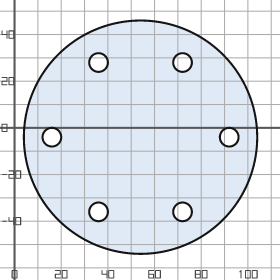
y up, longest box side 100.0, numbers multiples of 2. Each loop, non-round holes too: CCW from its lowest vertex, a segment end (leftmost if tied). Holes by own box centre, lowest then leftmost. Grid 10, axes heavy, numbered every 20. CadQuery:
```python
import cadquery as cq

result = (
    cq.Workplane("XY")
    .moveTo(54.0, -4.0)
    .circle(50.0)
    .moveTo(36.0, -36.0)
    .circle(4.0)
    .moveTo(72.0, -36.0)
    .circle(4.0)
    .moveTo(16.0, -4.0)
    .circle(4.0)
    .moveTo(92.0, -4.0)
    .circle(4.0)
    .moveTo(36.0, 28.0)
    .circle(4.0)
    .moveTo(72.0, 28.0)
    .circle(4.0)
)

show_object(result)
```